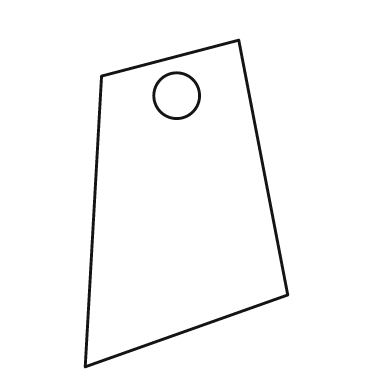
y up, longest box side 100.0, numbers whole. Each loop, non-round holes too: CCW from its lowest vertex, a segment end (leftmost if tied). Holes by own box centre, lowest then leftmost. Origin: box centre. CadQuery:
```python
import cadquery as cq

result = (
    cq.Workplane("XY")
    .moveTo(-31.0, -50.0)
    .lineTo(31.0, -28.0)
    .lineTo(16.0, 50.0)
    .lineTo(-26.0, 39.0)
    .close()
    .moveTo(-3.0, 33.0)
    .circle(7.0)
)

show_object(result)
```